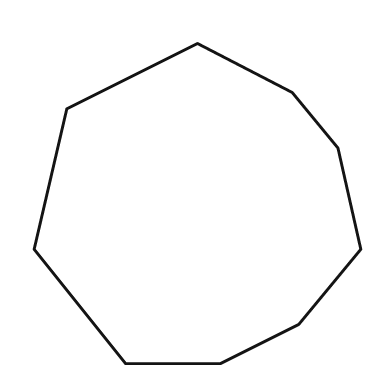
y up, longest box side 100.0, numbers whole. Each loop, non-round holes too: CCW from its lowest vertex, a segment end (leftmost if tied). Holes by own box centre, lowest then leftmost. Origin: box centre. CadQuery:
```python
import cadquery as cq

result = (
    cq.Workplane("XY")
    .moveTo(-22.0, -49.0)
    .lineTo(7.0, -49.0)
    .lineTo(31.0, -37.0)
    .lineTo(50.0, -14.0)
    .lineTo(43.0, 17.0)
    .lineTo(29.0, 34.0)
    .lineTo(0.0, 49.0)
    .lineTo(-40.0, 29.0)
    .lineTo(-50.0, -14.0)
    .close()
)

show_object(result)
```